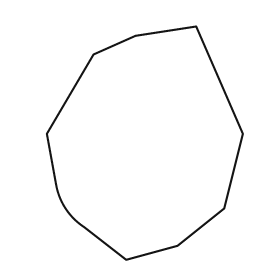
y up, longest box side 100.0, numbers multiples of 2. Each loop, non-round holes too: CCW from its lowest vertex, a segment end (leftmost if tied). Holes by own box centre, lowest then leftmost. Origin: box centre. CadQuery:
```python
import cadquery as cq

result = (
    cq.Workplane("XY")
    .moveTo(-8.0, -50.0)
    .lineTo(14.0, -44.0)
    .lineTo(34.0, -28.0)
    .lineTo(42.0, 4.0)
    .lineTo(22.0, 50.0)
    .lineTo(-4.0, 46.0)
    .lineTo(-22.0, 38.0)
    .lineTo(-42.0, 4.0)
    .lineTo(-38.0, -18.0)
    .threePointArc((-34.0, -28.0), (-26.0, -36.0))
    .close()
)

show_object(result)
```